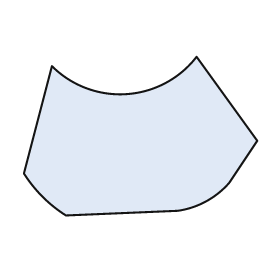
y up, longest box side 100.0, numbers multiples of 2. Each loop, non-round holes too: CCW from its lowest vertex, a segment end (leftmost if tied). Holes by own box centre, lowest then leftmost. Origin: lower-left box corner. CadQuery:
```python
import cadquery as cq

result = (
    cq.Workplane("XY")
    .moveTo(18.0, 0.0)
    .lineTo(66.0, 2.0)
    .threePointArc((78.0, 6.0), (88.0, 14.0))
    .lineTo(100.0, 32.0)
    .lineTo(74.0, 68.0)
    .threePointArc((44.0, 52.0), (12.0, 64.0))
    .lineTo(0.0, 18.0)
    .threePointArc((8.0, 8.0), (18.0, 0.0))
    .close()
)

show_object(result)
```